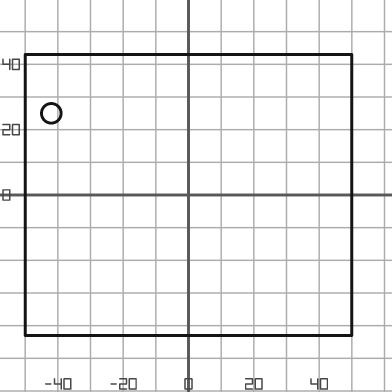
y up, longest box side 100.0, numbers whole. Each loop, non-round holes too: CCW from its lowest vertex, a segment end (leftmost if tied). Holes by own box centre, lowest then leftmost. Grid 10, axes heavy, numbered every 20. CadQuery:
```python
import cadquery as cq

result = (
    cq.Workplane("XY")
    .moveTo(-50.0, -43.0)
    .lineTo(50.0, -43.0)
    .lineTo(50.0, 43.0)
    .lineTo(-50.0, 43.0)
    .close()
    .moveTo(-42.0, 25.0)
    .circle(3.0)
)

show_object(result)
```